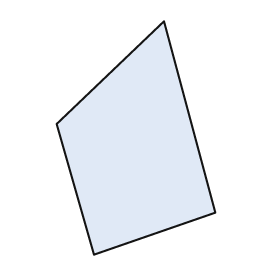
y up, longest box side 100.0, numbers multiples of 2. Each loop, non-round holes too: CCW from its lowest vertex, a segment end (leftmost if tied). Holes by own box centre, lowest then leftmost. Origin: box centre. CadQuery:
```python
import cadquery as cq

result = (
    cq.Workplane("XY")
    .moveTo(-18.0, -50.0)
    .lineTo(34.0, -32.0)
    .lineTo(12.0, 50.0)
    .lineTo(-34.0, 6.0)
    .close()
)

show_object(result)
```